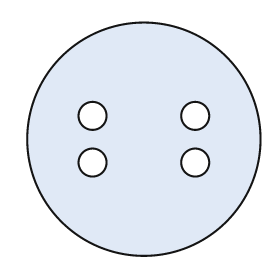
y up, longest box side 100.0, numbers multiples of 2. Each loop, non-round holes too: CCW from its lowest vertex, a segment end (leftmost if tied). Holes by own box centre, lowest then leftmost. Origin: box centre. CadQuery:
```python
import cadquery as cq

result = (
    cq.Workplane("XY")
    .moveTo(0.0, 0.0)
    .circle(50.0)
    .moveTo(-22.0, -10.0)
    .circle(6.0)
    .moveTo(22.0, -10.0)
    .circle(6.0)
    .moveTo(-22.0, 10.0)
    .circle(6.0)
    .moveTo(22.0, 10.0)
    .circle(6.0)
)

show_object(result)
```